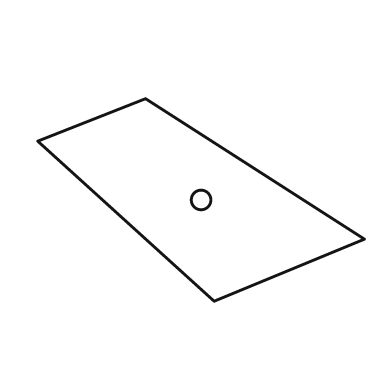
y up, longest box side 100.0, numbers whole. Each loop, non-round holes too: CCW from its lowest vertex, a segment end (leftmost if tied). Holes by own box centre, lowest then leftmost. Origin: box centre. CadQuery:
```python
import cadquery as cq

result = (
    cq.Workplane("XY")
    .moveTo(4.0, -31.0)
    .lineTo(50.0, -12.0)
    .lineTo(-17.0, 31.0)
    .lineTo(-50.0, 18.0)
    .close()
    .moveTo(0.0, 0.0)
    .circle(3.0)
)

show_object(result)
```